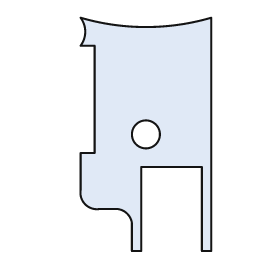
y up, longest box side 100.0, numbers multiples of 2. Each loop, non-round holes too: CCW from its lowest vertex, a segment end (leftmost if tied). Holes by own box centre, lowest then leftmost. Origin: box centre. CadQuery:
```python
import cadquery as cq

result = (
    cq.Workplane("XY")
    .moveTo(-6.0, -50.0)
    .lineTo(-2.0, -50.0)
    .lineTo(-2.0, -14.0)
    .lineTo(24.0, -14.0)
    .lineTo(24.0, -50.0)
    .lineTo(28.0, -50.0)
    .lineTo(28.0, 50.0)
    .threePointArc((0.0, 46.0), (-28.0, 50.0))
    .threePointArc((-26.0, 44.0), (-28.0, 38.0))
    .lineTo(-22.0, 38.0)
    .lineTo(-22.0, -8.0)
    .lineTo(-28.0, -8.0)
    .lineTo(-28.0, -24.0)
    .threePointArc((-26.0, -30.0), (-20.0, -32.0))
    .lineTo(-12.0, -32.0)
    .threePointArc((-8.0, -34.0), (-6.0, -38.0))
    .close()
    .moveTo(0.0, 0.0)
    .circle(6.0)
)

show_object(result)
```